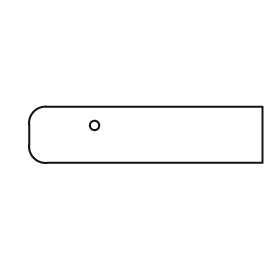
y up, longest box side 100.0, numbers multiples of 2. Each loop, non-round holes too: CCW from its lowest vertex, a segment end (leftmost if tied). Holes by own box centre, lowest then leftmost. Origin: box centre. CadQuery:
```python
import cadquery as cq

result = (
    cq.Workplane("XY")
    .moveTo(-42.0, -12.0)
    .lineTo(50.0, -12.0)
    .lineTo(50.0, 12.0)
    .lineTo(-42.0, 12.0)
    .threePointArc((-48.0, 10.0), (-50.0, 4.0))
    .lineTo(-50.0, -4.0)
    .threePointArc((-48.0, -10.0), (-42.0, -12.0))
    .close()
    .moveTo(-22.0, 4.0)
    .circle(2.0)
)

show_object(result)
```